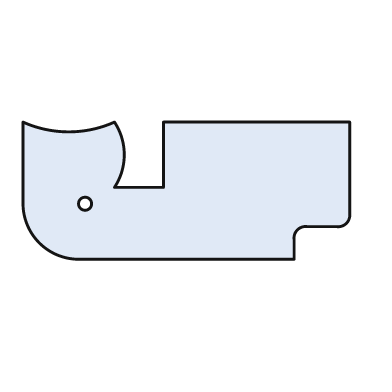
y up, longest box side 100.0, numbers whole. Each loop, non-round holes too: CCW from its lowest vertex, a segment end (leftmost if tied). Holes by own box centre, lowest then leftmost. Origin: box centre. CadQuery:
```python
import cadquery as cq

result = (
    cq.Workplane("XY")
    .moveTo(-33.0, -21.0)
    .lineTo(33.0, -21.0)
    .lineTo(33.0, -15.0)
    .threePointArc((34.0, -12.0), (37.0, -11.0))
    .lineTo(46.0, -11.0)
    .threePointArc((49.0, -10.0), (50.0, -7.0))
    .lineTo(50.0, 21.0)
    .lineTo(-7.0, 21.0)
    .lineTo(-7.0, 1.0)
    .lineTo(-22.0, 1.0)
    .threePointArc((-19.0, 11.0), (-22.0, 21.0))
    .threePointArc((-36.0, 18.0), (-50.0, 21.0))
    .lineTo(-50.0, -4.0)
    .threePointArc((-45.0, -16.0), (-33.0, -21.0))
    .close()
    .moveTo(-31.0, -4.0)
    .circle(2.0)
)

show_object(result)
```